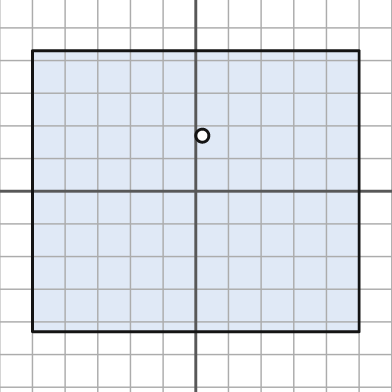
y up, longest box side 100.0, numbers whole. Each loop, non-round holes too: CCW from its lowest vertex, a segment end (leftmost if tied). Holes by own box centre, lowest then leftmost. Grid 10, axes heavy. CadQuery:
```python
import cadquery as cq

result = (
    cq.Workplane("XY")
    .moveTo(-50.0, -43.0)
    .lineTo(50.0, -43.0)
    .lineTo(50.0, 43.0)
    .lineTo(-50.0, 43.0)
    .close()
    .moveTo(2.0, 17.0)
    .circle(2.0)
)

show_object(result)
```